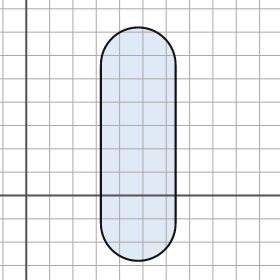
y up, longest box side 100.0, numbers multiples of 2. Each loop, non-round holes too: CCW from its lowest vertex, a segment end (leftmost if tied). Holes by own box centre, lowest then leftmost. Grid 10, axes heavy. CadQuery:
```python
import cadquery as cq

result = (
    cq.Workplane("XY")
    .moveTo(32.0, -12.0)
    .threePointArc((48.0, -28.0), (64.0, -12.0))
    .lineTo(64.0, 56.0)
    .threePointArc((48.0, 72.0), (32.0, 56.0))
    .close()
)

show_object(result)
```